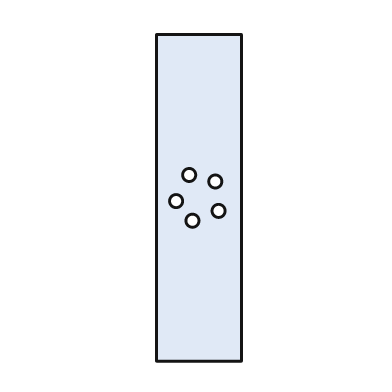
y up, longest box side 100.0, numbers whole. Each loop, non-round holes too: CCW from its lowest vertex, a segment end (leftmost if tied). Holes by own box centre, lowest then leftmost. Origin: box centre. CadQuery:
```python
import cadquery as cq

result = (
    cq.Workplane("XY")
    .moveTo(-13.0, -50.0)
    .lineTo(13.0, -50.0)
    .lineTo(13.0, 50.0)
    .lineTo(-13.0, 50.0)
    .close()
    .moveTo(-2.0, -7.0)
    .circle(2.0)
    .moveTo(6.0, -4.0)
    .circle(2.0)
    .moveTo(-7.0, -1.0)
    .circle(2.0)
    .moveTo(5.0, 5.0)
    .circle(2.0)
    .moveTo(-3.0, 7.0)
    .circle(2.0)
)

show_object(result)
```